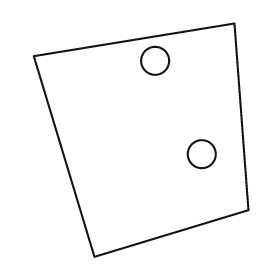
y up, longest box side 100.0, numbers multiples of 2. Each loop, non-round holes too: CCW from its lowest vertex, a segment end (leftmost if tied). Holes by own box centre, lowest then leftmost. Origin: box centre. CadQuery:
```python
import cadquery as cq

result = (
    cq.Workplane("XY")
    .moveTo(-20.0, -50.0)
    .lineTo(46.0, -30.0)
    .lineTo(40.0, 50.0)
    .lineTo(-46.0, 36.0)
    .close()
    .moveTo(26.0, -6.0)
    .circle(6.0)
    .moveTo(6.0, 34.0)
    .circle(6.0)
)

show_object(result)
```